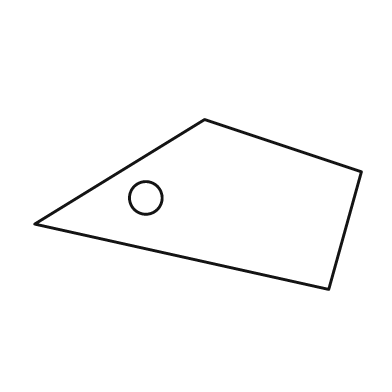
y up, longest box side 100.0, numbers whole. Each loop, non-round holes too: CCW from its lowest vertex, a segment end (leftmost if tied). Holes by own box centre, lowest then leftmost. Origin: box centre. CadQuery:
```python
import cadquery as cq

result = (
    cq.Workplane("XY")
    .moveTo(40.0, -26.0)
    .lineTo(50.0, 10.0)
    .lineTo(2.0, 26.0)
    .lineTo(-50.0, -6.0)
    .close()
    .moveTo(-16.0, 2.0)
    .circle(5.0)
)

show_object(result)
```